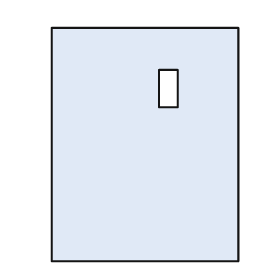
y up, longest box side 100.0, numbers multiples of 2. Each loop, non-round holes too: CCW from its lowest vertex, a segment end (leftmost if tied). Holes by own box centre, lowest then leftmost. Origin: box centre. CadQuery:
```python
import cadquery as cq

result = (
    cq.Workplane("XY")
    .moveTo(-40.0, -50.0)
    .lineTo(40.0, -50.0)
    .lineTo(40.0, 50.0)
    .lineTo(-40.0, 50.0)
    .close()
    .moveTo(6.0, 16.0)
    .lineTo(14.0, 16.0)
    .lineTo(14.0, 32.0)
    .lineTo(6.0, 32.0)
    .close()
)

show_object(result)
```